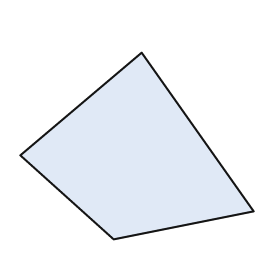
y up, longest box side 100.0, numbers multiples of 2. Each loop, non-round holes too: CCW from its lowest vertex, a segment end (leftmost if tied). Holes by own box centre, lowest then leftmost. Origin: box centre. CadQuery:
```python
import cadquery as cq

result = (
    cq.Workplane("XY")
    .moveTo(-10.0, -40.0)
    .lineTo(50.0, -28.0)
    .lineTo(2.0, 40.0)
    .lineTo(-50.0, -4.0)
    .close()
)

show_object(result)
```